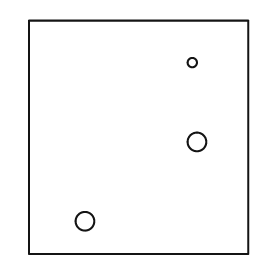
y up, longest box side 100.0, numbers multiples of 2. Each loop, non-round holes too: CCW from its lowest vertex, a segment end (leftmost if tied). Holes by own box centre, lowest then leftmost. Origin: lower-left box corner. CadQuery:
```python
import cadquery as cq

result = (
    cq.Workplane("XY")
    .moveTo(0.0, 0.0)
    .lineTo(94.0, 0.0)
    .lineTo(94.0, 100.0)
    .lineTo(0.0, 100.0)
    .close()
    .moveTo(24.0, 14.0)
    .circle(4.0)
    .moveTo(72.0, 48.0)
    .circle(4.0)
    .moveTo(70.0, 82.0)
    .circle(2.0)
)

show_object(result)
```